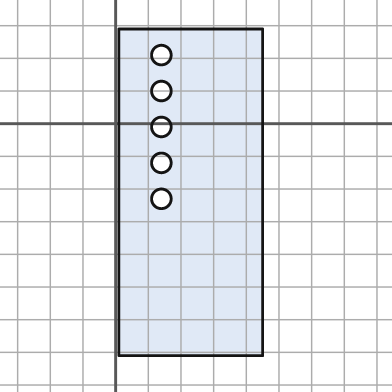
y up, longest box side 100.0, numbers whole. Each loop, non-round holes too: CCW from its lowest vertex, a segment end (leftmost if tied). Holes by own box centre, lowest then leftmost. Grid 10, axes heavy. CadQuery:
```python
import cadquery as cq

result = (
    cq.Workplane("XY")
    .moveTo(1.0, -71.0)
    .lineTo(45.0, -71.0)
    .lineTo(45.0, 29.0)
    .lineTo(1.0, 29.0)
    .close()
    .moveTo(14.0, -23.0)
    .circle(3.0)
    .moveTo(14.0, -12.0)
    .circle(3.0)
    .moveTo(14.0, -1.0)
    .circle(3.0)
    .moveTo(14.0, 10.0)
    .circle(3.0)
    .moveTo(14.0, 21.0)
    .circle(3.0)
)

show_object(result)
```